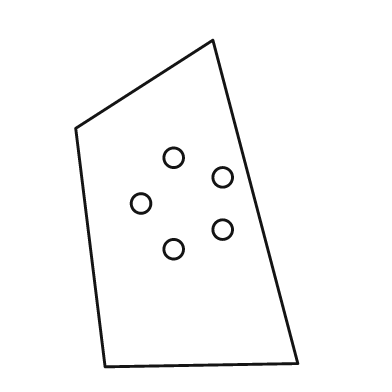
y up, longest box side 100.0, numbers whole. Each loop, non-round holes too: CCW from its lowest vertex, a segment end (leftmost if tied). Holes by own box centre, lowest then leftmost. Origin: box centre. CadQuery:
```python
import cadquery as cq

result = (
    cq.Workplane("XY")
    .moveTo(-25.0, -50.0)
    .lineTo(34.0, -49.0)
    .lineTo(8.0, 50.0)
    .lineTo(-34.0, 23.0)
    .close()
    .moveTo(-4.0, -14.0)
    .circle(3.0)
    .moveTo(11.0, -8.0)
    .circle(3.0)
    .moveTo(-14.0, 0.0)
    .circle(3.0)
    .moveTo(11.0, 8.0)
    .circle(3.0)
    .moveTo(-4.0, 14.0)
    .circle(3.0)
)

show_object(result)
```